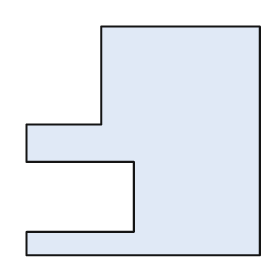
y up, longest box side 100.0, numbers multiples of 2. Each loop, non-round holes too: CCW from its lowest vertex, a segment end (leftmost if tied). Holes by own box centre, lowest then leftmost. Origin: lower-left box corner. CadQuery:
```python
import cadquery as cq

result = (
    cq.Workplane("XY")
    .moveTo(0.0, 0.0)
    .lineTo(100.0, 0.0)
    .lineTo(100.0, 98.0)
    .lineTo(32.0, 98.0)
    .lineTo(32.0, 56.0)
    .lineTo(0.0, 56.0)
    .lineTo(0.0, 40.0)
    .lineTo(46.0, 40.0)
    .lineTo(46.0, 10.0)
    .lineTo(0.0, 10.0)
    .close()
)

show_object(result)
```